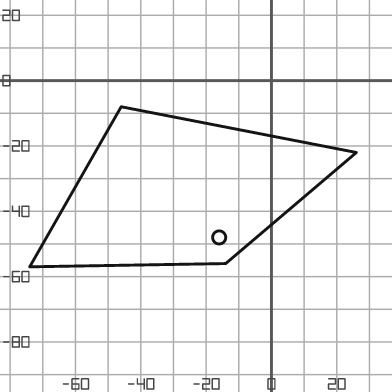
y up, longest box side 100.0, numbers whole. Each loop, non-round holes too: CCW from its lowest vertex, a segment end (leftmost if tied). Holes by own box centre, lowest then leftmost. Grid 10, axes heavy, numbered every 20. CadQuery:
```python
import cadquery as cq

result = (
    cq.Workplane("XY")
    .moveTo(-74.0, -57.0)
    .lineTo(-14.0, -56.0)
    .lineTo(26.0, -22.0)
    .lineTo(-46.0, -8.0)
    .close()
    .moveTo(-16.0, -48.0)
    .circle(2.0)
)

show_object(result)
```